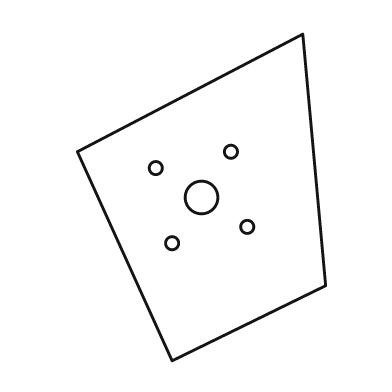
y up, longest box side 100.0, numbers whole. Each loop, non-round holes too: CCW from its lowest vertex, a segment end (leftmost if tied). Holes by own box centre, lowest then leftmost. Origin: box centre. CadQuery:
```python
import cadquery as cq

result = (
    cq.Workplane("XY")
    .moveTo(-9.0, -50.0)
    .lineTo(38.0, -27.0)
    .lineTo(31.0, 50.0)
    .lineTo(-38.0, 14.0)
    .close()
    .moveTo(-9.0, -14.0)
    .circle(2.0)
    .moveTo(14.0, -9.0)
    .circle(2.0)
    .moveTo(0.0, 0.0)
    .circle(5.0)
    .moveTo(-14.0, 9.0)
    .circle(2.0)
    .moveTo(9.0, 14.0)
    .circle(2.0)
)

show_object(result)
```